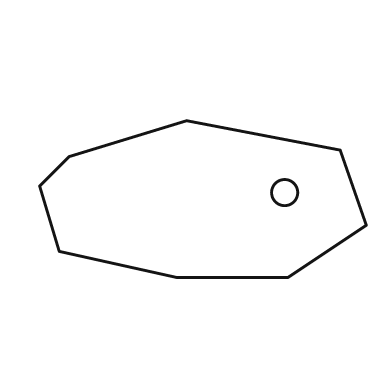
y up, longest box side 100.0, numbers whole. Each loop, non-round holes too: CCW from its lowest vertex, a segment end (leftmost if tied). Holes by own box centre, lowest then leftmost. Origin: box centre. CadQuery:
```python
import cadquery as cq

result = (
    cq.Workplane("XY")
    .moveTo(-8.0, -24.0)
    .lineTo(26.0, -24.0)
    .lineTo(50.0, -8.0)
    .lineTo(42.0, 15.0)
    .lineTo(-5.0, 24.0)
    .lineTo(-41.0, 13.0)
    .lineTo(-50.0, 4.0)
    .lineTo(-44.0, -16.0)
    .close()
    .moveTo(25.0, 2.0)
    .circle(4.0)
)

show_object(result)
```